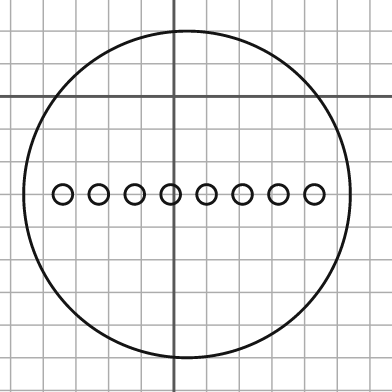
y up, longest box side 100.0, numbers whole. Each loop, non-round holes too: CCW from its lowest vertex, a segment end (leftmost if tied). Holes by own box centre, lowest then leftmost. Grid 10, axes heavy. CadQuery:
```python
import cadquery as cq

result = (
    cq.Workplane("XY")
    .moveTo(4.0, -30.0)
    .circle(50.0)
    .moveTo(-34.0, -30.0)
    .circle(3.0)
    .moveTo(-23.0, -30.0)
    .circle(3.0)
    .moveTo(-12.0, -30.0)
    .circle(3.0)
    .moveTo(-1.0, -30.0)
    .circle(3.0)
    .moveTo(10.0, -30.0)
    .circle(3.0)
    .moveTo(21.0, -30.0)
    .circle(3.0)
    .moveTo(32.0, -30.0)
    .circle(3.0)
    .moveTo(43.0, -30.0)
    .circle(3.0)
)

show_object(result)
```